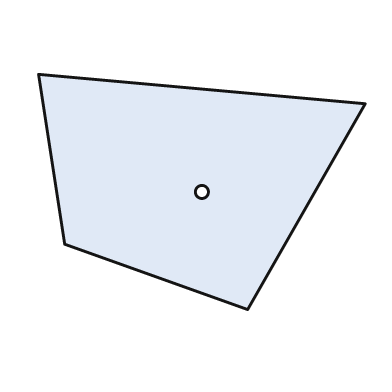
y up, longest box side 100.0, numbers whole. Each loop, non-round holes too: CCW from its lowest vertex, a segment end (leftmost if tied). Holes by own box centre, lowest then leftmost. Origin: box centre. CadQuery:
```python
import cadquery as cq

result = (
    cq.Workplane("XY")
    .moveTo(14.0, -36.0)
    .lineTo(50.0, 27.0)
    .lineTo(-50.0, 36.0)
    .lineTo(-42.0, -16.0)
    .close()
    .moveTo(0.0, 0.0)
    .circle(2.0)
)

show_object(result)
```